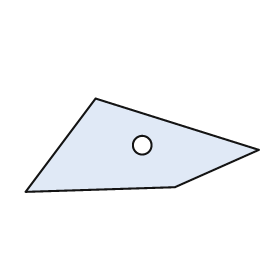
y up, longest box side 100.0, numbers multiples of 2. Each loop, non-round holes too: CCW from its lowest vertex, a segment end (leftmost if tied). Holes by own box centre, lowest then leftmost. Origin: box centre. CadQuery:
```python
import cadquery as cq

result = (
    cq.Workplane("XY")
    .moveTo(-50.0, -20.0)
    .lineTo(14.0, -18.0)
    .lineTo(50.0, -2.0)
    .lineTo(-20.0, 20.0)
    .close()
    .moveTo(0.0, 0.0)
    .circle(4.0)
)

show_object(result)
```